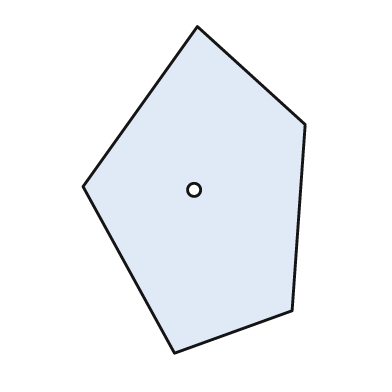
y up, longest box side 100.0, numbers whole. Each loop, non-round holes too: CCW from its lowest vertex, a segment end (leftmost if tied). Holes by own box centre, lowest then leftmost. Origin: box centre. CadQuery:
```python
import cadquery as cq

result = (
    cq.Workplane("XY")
    .moveTo(-6.0, -50.0)
    .lineTo(30.0, -37.0)
    .lineTo(34.0, 20.0)
    .lineTo(1.0, 50.0)
    .lineTo(-34.0, 1.0)
    .close()
    .moveTo(0.0, 0.0)
    .circle(2.0)
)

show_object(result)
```